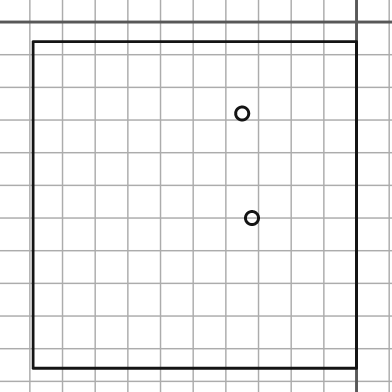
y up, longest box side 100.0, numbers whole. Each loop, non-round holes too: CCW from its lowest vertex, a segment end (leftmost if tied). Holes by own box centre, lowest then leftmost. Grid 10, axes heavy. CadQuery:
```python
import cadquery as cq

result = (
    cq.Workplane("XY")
    .moveTo(-99.0, -106.0)
    .lineTo(0.0, -106.0)
    .lineTo(0.0, -6.0)
    .lineTo(-99.0, -6.0)
    .close()
    .moveTo(-32.0, -60.0)
    .circle(2.0)
    .moveTo(-35.0, -28.0)
    .circle(2.0)
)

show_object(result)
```